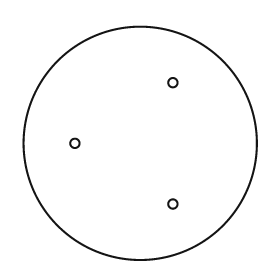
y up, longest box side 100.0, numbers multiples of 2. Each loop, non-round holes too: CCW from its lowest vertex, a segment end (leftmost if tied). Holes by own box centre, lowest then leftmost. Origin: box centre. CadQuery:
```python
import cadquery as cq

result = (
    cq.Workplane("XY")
    .moveTo(0.0, 0.0)
    .circle(50.0)
    .moveTo(14.0, -26.0)
    .circle(2.0)
    .moveTo(-28.0, 0.0)
    .circle(2.0)
    .moveTo(14.0, 26.0)
    .circle(2.0)
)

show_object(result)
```